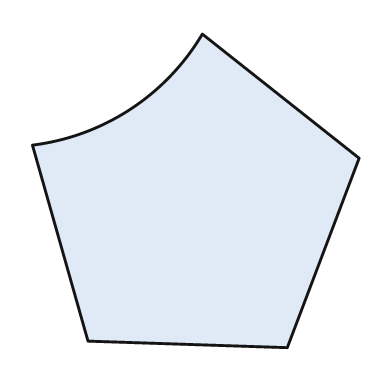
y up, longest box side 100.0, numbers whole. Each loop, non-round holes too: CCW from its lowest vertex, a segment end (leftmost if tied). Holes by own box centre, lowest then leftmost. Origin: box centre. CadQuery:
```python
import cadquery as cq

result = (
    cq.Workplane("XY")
    .moveTo(28.0, -48.0)
    .lineTo(50.0, 10.0)
    .lineTo(2.0, 48.0)
    .threePointArc((-20.0, 25.0), (-50.0, 14.0))
    .lineTo(-33.0, -46.0)
    .close()
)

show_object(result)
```